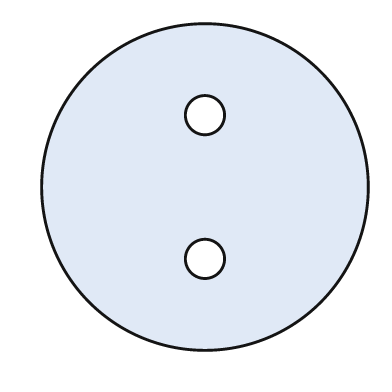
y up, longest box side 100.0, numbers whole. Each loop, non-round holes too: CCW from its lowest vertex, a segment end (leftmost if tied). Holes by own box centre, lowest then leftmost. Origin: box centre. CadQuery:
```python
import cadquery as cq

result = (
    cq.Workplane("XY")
    .moveTo(0.0, 0.0)
    .circle(50.0)
    .moveTo(0.0, -22.0)
    .circle(6.0)
    .moveTo(0.0, 22.0)
    .circle(6.0)
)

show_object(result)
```